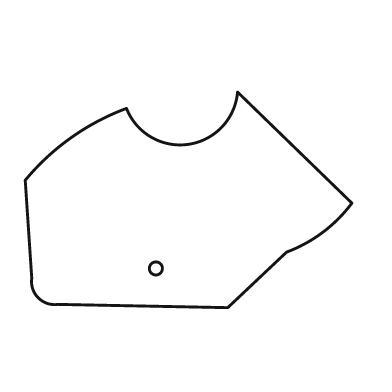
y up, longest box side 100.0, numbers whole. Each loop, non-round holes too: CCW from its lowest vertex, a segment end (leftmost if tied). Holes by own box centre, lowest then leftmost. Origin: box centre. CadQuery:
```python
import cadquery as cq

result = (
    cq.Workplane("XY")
    .moveTo(12.0, -33.0)
    .lineTo(30.0, -16.0)
    .threePointArc((41.0, -10.0), (50.0, -1.0))
    .lineTo(15.0, 33.0)
    .threePointArc((0.0, 17.0), (-19.0, 28.0))
    .threePointArc((-36.0, 19.0), (-50.0, 6.0))
    .lineTo(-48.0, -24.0)
    .threePointArc((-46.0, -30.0), (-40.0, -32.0))
    .close()
    .moveTo(-10.0, -21.0)
    .circle(2.0)
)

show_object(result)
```